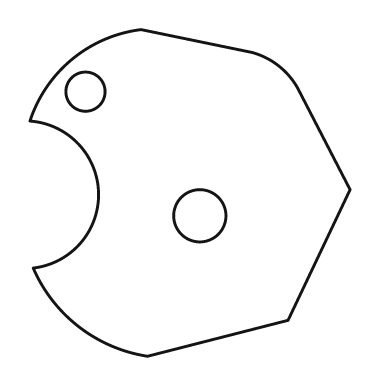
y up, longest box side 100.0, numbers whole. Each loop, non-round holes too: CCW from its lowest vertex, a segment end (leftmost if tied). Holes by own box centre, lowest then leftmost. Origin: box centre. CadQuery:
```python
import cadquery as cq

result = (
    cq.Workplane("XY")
    .moveTo(-13.0, -50.0)
    .lineTo(30.0, -39.0)
    .lineTo(49.0, 1.0)
    .lineTo(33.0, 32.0)
    .threePointArc((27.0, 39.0), (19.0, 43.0))
    .lineTo(-15.0, 50.0)
    .threePointArc((-36.0, 41.0), (-49.0, 22.0))
    .threePointArc((-28.0, 0.0), (-48.0, -23.0))
    .threePointArc((-34.0, -41.0), (-13.0, -50.0))
    .close()
    .moveTo(3.0, -7.0)
    .circle(8.0)
    .moveTo(-32.0, 31.0)
    .circle(6.0)
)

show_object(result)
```